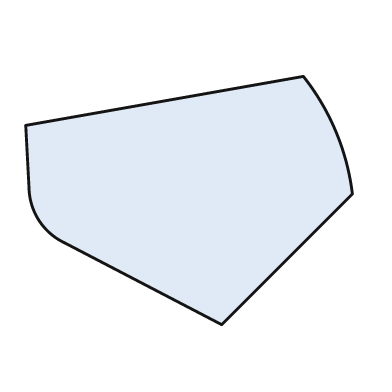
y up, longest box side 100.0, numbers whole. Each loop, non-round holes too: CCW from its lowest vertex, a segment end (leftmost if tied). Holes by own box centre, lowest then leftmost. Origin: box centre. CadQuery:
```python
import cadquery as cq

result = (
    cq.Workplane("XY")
    .moveTo(10.0, -38.0)
    .lineTo(50.0, 2.0)
    .threePointArc((45.0, 21.0), (35.0, 38.0))
    .lineTo(-50.0, 23.0)
    .lineTo(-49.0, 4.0)
    .threePointArc((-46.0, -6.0), (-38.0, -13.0))
    .close()
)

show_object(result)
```